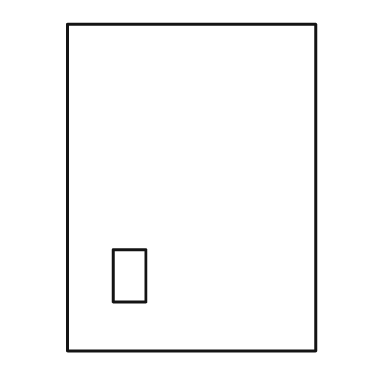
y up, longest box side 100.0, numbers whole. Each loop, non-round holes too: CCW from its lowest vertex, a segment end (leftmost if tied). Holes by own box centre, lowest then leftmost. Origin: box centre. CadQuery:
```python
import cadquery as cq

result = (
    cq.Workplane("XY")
    .moveTo(-38.0, -50.0)
    .lineTo(38.0, -50.0)
    .lineTo(38.0, 50.0)
    .lineTo(-38.0, 50.0)
    .close()
    .moveTo(-24.0, -35.0)
    .lineTo(-14.0, -35.0)
    .lineTo(-14.0, -19.0)
    .lineTo(-24.0, -19.0)
    .close()
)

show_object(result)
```